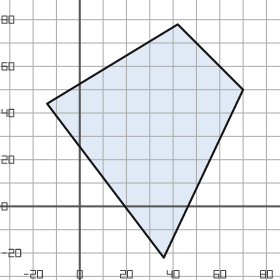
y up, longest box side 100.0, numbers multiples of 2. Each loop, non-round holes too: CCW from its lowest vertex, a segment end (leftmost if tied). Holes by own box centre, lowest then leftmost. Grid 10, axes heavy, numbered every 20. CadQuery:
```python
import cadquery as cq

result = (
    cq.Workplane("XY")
    .moveTo(36.0, -22.0)
    .lineTo(70.0, 50.0)
    .lineTo(42.0, 78.0)
    .lineTo(-14.0, 44.0)
    .close()
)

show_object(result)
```